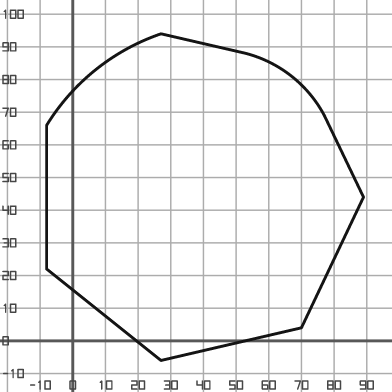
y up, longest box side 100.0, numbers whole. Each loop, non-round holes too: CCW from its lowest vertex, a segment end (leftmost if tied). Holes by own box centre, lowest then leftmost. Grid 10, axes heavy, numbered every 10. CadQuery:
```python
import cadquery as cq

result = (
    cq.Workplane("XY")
    .moveTo(27.0, -6.0)
    .lineTo(70.0, 4.0)
    .lineTo(89.0, 44.0)
    .lineTo(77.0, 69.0)
    .threePointArc((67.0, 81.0), (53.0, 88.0))
    .lineTo(27.0, 94.0)
    .threePointArc((7.0, 83.0), (-8.0, 66.0))
    .lineTo(-8.0, 22.0)
    .close()
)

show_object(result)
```